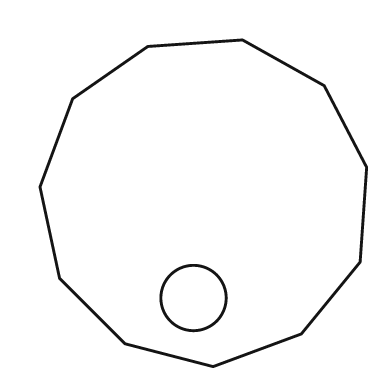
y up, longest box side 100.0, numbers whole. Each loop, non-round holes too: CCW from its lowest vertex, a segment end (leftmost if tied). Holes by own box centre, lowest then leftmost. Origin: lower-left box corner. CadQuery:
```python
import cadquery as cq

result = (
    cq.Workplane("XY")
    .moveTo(53.0, 0.0)
    .lineTo(80.0, 10.0)
    .lineTo(98.0, 32.0)
    .lineTo(100.0, 61.0)
    .lineTo(87.0, 86.0)
    .lineTo(62.0, 100.0)
    .lineTo(33.0, 98.0)
    .lineTo(10.0, 82.0)
    .lineTo(0.0, 55.0)
    .lineTo(6.0, 27.0)
    .lineTo(26.0, 7.0)
    .close()
    .moveTo(47.0, 21.0)
    .circle(10.0)
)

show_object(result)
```